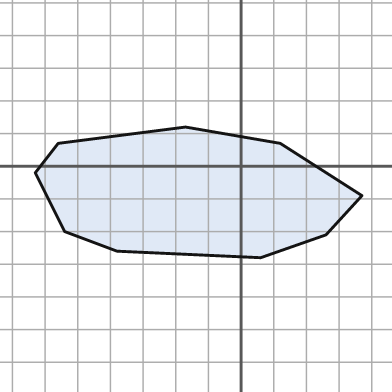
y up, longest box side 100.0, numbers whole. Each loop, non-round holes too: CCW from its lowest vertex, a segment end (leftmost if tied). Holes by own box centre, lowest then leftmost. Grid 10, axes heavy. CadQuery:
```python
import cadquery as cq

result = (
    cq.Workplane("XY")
    .moveTo(6.0, -28.0)
    .lineTo(26.0, -21.0)
    .lineTo(37.0, -9.0)
    .lineTo(12.0, 7.0)
    .lineTo(-17.0, 12.0)
    .lineTo(-56.0, 7.0)
    .lineTo(-63.0, -2.0)
    .lineTo(-54.0, -20.0)
    .lineTo(-38.0, -26.0)
    .close()
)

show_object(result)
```